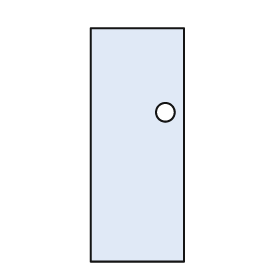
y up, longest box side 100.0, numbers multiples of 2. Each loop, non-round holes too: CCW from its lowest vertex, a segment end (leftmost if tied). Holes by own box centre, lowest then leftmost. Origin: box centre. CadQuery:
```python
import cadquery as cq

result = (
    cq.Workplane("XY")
    .moveTo(-20.0, -50.0)
    .lineTo(20.0, -50.0)
    .lineTo(20.0, 50.0)
    .lineTo(-20.0, 50.0)
    .close()
    .moveTo(12.0, 14.0)
    .circle(4.0)
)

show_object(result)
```